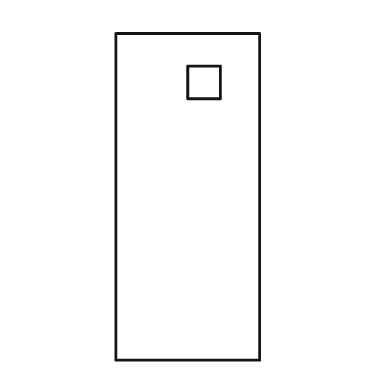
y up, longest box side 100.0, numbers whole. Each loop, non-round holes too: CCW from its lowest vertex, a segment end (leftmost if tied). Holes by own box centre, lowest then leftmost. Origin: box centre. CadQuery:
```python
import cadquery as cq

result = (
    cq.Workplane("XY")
    .moveTo(-22.0, -50.0)
    .lineTo(22.0, -50.0)
    .lineTo(22.0, 50.0)
    .lineTo(-22.0, 50.0)
    .close()
    .moveTo(0.0, 30.0)
    .lineTo(10.0, 30.0)
    .lineTo(10.0, 40.0)
    .lineTo(0.0, 40.0)
    .close()
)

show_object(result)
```